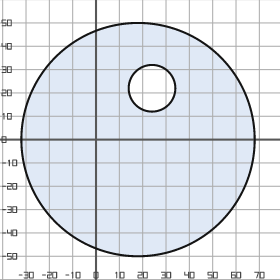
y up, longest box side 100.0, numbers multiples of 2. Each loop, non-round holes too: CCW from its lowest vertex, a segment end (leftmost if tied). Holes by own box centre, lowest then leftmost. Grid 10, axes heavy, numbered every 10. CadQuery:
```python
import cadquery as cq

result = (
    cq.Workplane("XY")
    .moveTo(18.0, 0.0)
    .circle(50.0)
    .moveTo(24.0, 22.0)
    .circle(10.0)
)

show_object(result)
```